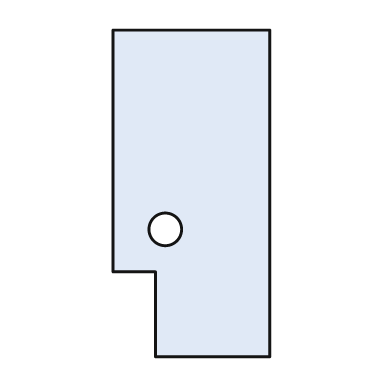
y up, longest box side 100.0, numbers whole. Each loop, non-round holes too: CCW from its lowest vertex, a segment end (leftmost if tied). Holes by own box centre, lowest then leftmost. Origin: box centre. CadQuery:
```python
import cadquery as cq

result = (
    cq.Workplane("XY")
    .moveTo(-11.0, -50.0)
    .lineTo(24.0, -50.0)
    .lineTo(24.0, 50.0)
    .lineTo(-24.0, 50.0)
    .lineTo(-24.0, -24.0)
    .lineTo(-11.0, -24.0)
    .close()
    .moveTo(-8.0, -11.0)
    .circle(5.0)
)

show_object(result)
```